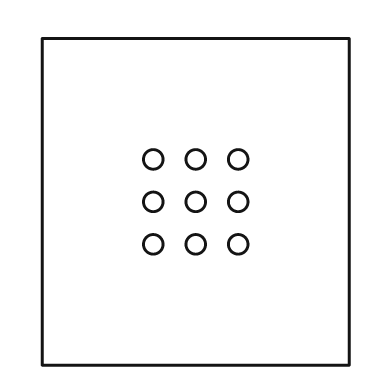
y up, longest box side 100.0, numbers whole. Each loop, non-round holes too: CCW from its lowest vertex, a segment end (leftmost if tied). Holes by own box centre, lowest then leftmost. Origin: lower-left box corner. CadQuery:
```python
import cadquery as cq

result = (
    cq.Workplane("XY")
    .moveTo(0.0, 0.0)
    .lineTo(94.0, 0.0)
    .lineTo(94.0, 100.0)
    .lineTo(0.0, 100.0)
    .close()
    .moveTo(34.0, 37.0)
    .circle(3.0)
    .moveTo(47.0, 37.0)
    .circle(3.0)
    .moveTo(60.0, 37.0)
    .circle(3.0)
    .moveTo(34.0, 50.0)
    .circle(3.0)
    .moveTo(47.0, 50.0)
    .circle(3.0)
    .moveTo(60.0, 50.0)
    .circle(3.0)
    .moveTo(34.0, 63.0)
    .circle(3.0)
    .moveTo(47.0, 63.0)
    .circle(3.0)
    .moveTo(60.0, 63.0)
    .circle(3.0)
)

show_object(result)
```